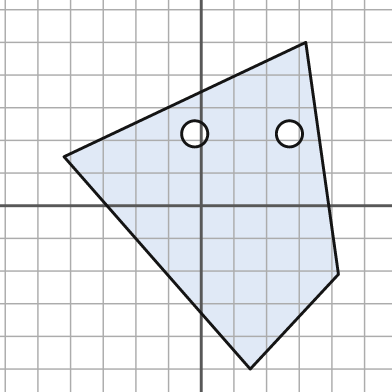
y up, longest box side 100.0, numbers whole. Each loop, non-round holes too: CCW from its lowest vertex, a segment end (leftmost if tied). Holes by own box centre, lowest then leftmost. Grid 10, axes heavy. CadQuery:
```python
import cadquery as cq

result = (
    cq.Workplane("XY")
    .moveTo(15.0, -50.0)
    .lineTo(42.0, -21.0)
    .lineTo(32.0, 50.0)
    .lineTo(-42.0, 15.0)
    .close()
    .moveTo(-2.0, 22.0)
    .circle(4.0)
    .moveTo(27.0, 22.0)
    .circle(4.0)
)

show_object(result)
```